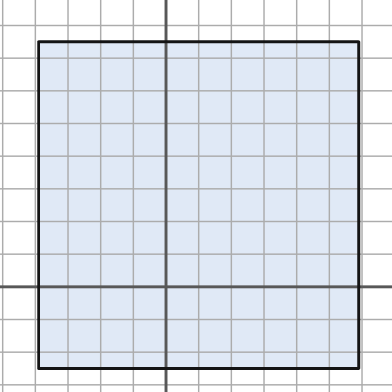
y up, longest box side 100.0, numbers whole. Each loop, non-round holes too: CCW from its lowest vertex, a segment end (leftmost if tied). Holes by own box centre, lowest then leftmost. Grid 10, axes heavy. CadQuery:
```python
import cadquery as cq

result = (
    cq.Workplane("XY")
    .moveTo(-39.0, -25.0)
    .lineTo(59.0, -25.0)
    .lineTo(59.0, 75.0)
    .lineTo(-39.0, 75.0)
    .close()
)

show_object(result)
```